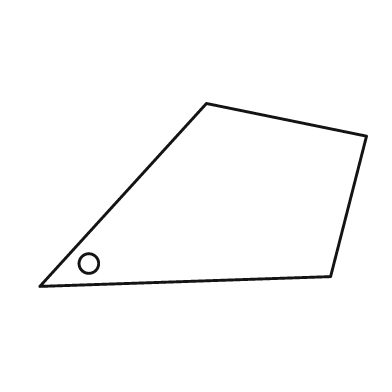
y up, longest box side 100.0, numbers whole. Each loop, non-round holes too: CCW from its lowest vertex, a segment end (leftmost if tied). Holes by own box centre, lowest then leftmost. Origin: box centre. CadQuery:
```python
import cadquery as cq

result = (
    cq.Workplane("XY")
    .moveTo(-50.0, -28.0)
    .lineTo(39.0, -25.0)
    .lineTo(50.0, 18.0)
    .lineTo(1.0, 28.0)
    .close()
    .moveTo(-35.0, -21.0)
    .circle(3.0)
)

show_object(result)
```